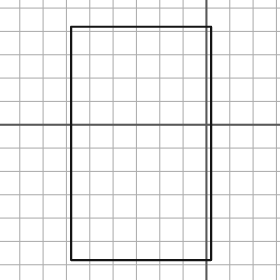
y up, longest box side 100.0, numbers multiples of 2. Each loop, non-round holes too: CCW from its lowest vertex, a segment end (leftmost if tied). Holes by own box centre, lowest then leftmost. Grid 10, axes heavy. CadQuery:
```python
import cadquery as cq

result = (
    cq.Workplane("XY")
    .moveTo(-58.0, -58.0)
    .lineTo(2.0, -58.0)
    .lineTo(2.0, 42.0)
    .lineTo(-58.0, 42.0)
    .close()
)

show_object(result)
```